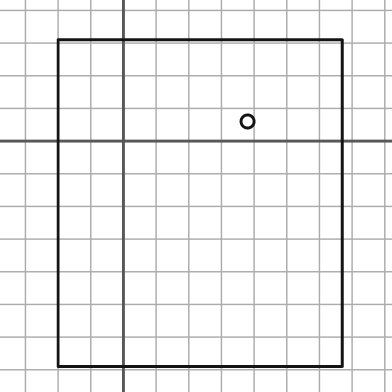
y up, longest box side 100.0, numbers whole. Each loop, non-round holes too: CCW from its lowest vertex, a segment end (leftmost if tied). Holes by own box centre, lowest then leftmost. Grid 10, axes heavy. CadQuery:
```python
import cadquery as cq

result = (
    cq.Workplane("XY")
    .moveTo(-20.0, -69.0)
    .lineTo(67.0, -69.0)
    .lineTo(67.0, 31.0)
    .lineTo(-20.0, 31.0)
    .close()
    .moveTo(38.0, 6.0)
    .circle(2.0)
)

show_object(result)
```